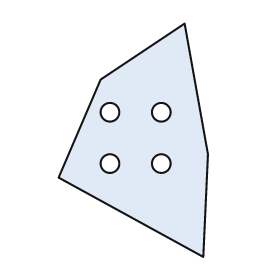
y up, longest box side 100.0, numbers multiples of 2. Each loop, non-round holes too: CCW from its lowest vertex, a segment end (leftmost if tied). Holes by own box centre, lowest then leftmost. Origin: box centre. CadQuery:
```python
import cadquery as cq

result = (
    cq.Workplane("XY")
    .moveTo(30.0, -50.0)
    .lineTo(32.0, -6.0)
    .lineTo(22.0, 50.0)
    .lineTo(-14.0, 26.0)
    .lineTo(-32.0, -16.0)
    .close()
    .moveTo(-10.0, -10.0)
    .circle(4.0)
    .moveTo(12.0, -10.0)
    .circle(4.0)
    .moveTo(-10.0, 12.0)
    .circle(4.0)
    .moveTo(12.0, 12.0)
    .circle(4.0)
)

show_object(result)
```